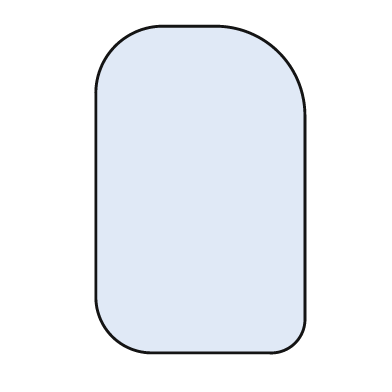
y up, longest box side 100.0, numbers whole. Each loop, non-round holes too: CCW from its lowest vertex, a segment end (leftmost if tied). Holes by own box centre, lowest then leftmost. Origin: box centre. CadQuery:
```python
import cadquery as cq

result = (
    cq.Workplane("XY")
    .moveTo(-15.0, -50.0)
    .lineTo(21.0, -50.0)
    .threePointArc((29.0, -47.0), (32.0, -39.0))
    .lineTo(32.0, 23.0)
    .threePointArc((24.0, 42.0), (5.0, 50.0))
    .lineTo(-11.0, 50.0)
    .threePointArc((-26.0, 44.0), (-32.0, 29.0))
    .lineTo(-32.0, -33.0)
    .threePointArc((-27.0, -45.0), (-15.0, -50.0))
    .close()
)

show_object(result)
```